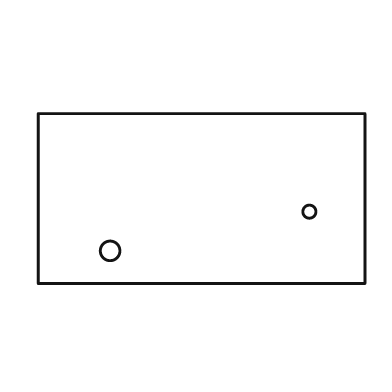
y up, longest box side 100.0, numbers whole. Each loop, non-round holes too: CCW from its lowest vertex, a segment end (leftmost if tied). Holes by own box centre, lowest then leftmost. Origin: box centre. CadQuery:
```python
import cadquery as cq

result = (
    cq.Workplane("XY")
    .moveTo(-50.0, -26.0)
    .lineTo(50.0, -26.0)
    .lineTo(50.0, 26.0)
    .lineTo(-50.0, 26.0)
    .close()
    .moveTo(-28.0, -16.0)
    .circle(3.0)
    .moveTo(33.0, -4.0)
    .circle(2.0)
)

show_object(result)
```